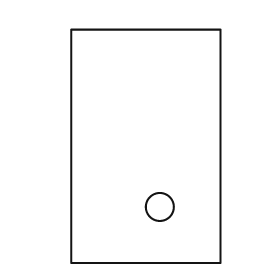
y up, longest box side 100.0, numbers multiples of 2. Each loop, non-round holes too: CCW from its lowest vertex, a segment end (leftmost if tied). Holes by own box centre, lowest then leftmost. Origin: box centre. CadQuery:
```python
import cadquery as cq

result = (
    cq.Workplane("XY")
    .moveTo(-32.0, -50.0)
    .lineTo(32.0, -50.0)
    .lineTo(32.0, 50.0)
    .lineTo(-32.0, 50.0)
    .close()
    .moveTo(6.0, -26.0)
    .circle(6.0)
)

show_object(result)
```